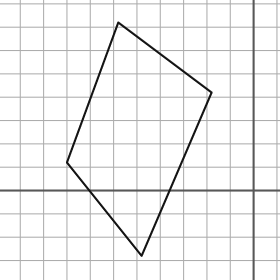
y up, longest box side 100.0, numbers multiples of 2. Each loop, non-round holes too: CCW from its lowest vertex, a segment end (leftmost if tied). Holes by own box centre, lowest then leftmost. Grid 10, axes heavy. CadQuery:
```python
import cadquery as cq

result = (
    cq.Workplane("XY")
    .moveTo(-48.0, -28.0)
    .lineTo(-18.0, 42.0)
    .lineTo(-58.0, 72.0)
    .lineTo(-80.0, 12.0)
    .close()
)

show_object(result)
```